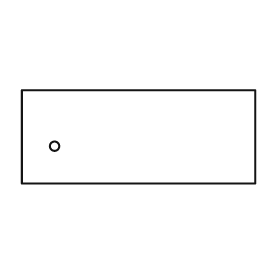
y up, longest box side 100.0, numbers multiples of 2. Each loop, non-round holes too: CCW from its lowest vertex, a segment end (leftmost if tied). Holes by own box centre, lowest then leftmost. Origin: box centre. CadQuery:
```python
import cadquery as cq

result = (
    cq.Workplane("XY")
    .moveTo(-50.0, -20.0)
    .lineTo(50.0, -20.0)
    .lineTo(50.0, 20.0)
    .lineTo(-50.0, 20.0)
    .close()
    .moveTo(-36.0, -4.0)
    .circle(2.0)
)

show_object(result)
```